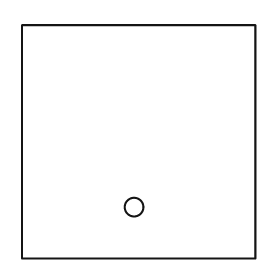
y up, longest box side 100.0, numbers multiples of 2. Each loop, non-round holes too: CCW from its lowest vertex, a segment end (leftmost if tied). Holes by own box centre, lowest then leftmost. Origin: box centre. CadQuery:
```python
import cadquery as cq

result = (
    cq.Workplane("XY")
    .moveTo(-50.0, -50.0)
    .lineTo(50.0, -50.0)
    .lineTo(50.0, 50.0)
    .lineTo(-50.0, 50.0)
    .close()
    .moveTo(-2.0, -28.0)
    .circle(4.0)
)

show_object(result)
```